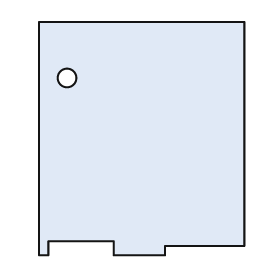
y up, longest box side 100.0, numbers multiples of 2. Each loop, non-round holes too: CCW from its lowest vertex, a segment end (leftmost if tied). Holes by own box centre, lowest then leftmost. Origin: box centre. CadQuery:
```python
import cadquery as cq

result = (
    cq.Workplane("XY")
    .moveTo(-44.0, -50.0)
    .lineTo(-40.0, -50.0)
    .lineTo(-40.0, -44.0)
    .lineTo(-12.0, -44.0)
    .lineTo(-12.0, -50.0)
    .lineTo(10.0, -50.0)
    .lineTo(10.0, -46.0)
    .lineTo(44.0, -46.0)
    .lineTo(44.0, 50.0)
    .lineTo(-44.0, 50.0)
    .close()
    .moveTo(-32.0, 26.0)
    .circle(4.0)
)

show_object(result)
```